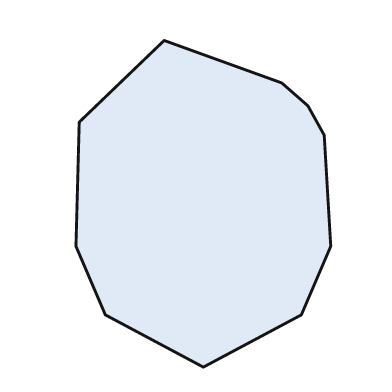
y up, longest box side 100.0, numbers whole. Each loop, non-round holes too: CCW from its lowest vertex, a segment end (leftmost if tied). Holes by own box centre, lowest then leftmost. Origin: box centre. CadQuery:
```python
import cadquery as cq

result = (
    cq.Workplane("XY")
    .moveTo(0.0, -50.0)
    .lineTo(30.0, -34.0)
    .lineTo(39.0, -13.0)
    .lineTo(37.0, 21.0)
    .lineTo(32.0, 30.0)
    .lineTo(24.0, 37.0)
    .lineTo(-12.0, 50.0)
    .lineTo(-38.0, 25.0)
    .lineTo(-39.0, -13.0)
    .lineTo(-30.0, -34.0)
    .close()
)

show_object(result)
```